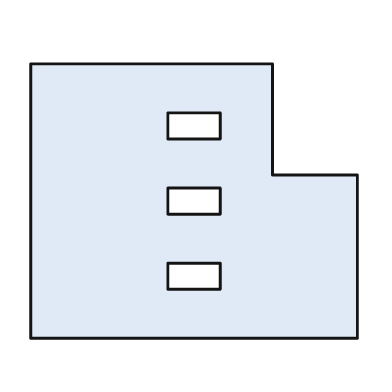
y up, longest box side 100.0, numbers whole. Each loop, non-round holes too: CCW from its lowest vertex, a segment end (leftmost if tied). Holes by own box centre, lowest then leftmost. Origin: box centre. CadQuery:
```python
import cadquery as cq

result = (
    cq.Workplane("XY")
    .moveTo(-50.0, -42.0)
    .lineTo(50.0, -42.0)
    .lineTo(50.0, 8.0)
    .lineTo(24.0, 8.0)
    .lineTo(24.0, 42.0)
    .lineTo(-50.0, 42.0)
    .close()
    .moveTo(-8.0, -27.0)
    .lineTo(8.0, -27.0)
    .lineTo(8.0, -19.0)
    .lineTo(-8.0, -19.0)
    .close()
    .moveTo(-8.0, -4.0)
    .lineTo(8.0, -4.0)
    .lineTo(8.0, 4.0)
    .lineTo(-8.0, 4.0)
    .close()
    .moveTo(-8.0, 19.0)
    .lineTo(8.0, 19.0)
    .lineTo(8.0, 27.0)
    .lineTo(-8.0, 27.0)
    .close()
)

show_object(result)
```